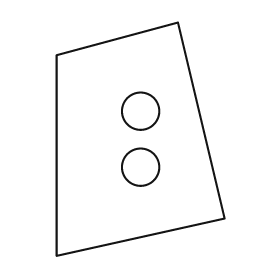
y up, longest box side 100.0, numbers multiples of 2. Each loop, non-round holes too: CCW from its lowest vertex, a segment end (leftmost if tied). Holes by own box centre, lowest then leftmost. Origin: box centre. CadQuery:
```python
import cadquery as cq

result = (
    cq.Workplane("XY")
    .moveTo(-36.0, -50.0)
    .lineTo(36.0, -34.0)
    .lineTo(16.0, 50.0)
    .lineTo(-36.0, 36.0)
    .close()
    .moveTo(0.0, -12.0)
    .circle(8.0)
    .moveTo(0.0, 12.0)
    .circle(8.0)
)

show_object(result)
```